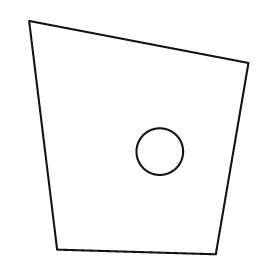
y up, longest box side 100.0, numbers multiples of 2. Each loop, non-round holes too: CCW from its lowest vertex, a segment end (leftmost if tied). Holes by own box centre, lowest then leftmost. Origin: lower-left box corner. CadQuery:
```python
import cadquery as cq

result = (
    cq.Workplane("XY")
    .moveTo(80.0, 0.0)
    .lineTo(94.0, 82.0)
    .lineTo(0.0, 100.0)
    .lineTo(12.0, 2.0)
    .close()
    .moveTo(56.0, 44.0)
    .circle(10.0)
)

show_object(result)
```